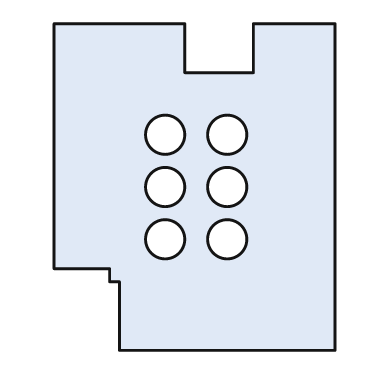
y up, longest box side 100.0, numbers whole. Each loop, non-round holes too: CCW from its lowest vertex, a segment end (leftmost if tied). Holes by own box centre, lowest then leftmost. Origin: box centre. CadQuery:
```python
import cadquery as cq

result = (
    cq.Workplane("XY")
    .moveTo(-23.0, -50.0)
    .lineTo(43.0, -50.0)
    .lineTo(43.0, 50.0)
    .lineTo(18.0, 50.0)
    .lineTo(18.0, 35.0)
    .lineTo(-3.0, 35.0)
    .lineTo(-3.0, 50.0)
    .lineTo(-43.0, 50.0)
    .lineTo(-43.0, -25.0)
    .lineTo(-26.0, -25.0)
    .lineTo(-26.0, -29.0)
    .lineTo(-23.0, -29.0)
    .close()
    .moveTo(-9.0, -16.0)
    .circle(6.0)
    .moveTo(10.0, -16.0)
    .circle(6.0)
    .moveTo(-9.0, 0.0)
    .circle(6.0)
    .moveTo(10.0, 0.0)
    .circle(6.0)
    .moveTo(-9.0, 16.0)
    .circle(6.0)
    .moveTo(10.0, 16.0)
    .circle(6.0)
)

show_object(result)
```